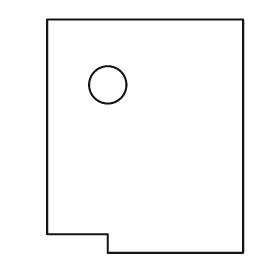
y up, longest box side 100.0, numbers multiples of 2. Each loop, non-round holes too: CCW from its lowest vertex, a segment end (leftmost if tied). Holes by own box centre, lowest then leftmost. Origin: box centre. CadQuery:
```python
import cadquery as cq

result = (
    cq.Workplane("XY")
    .moveTo(-16.0, -50.0)
    .lineTo(42.0, -50.0)
    .lineTo(42.0, 50.0)
    .lineTo(-42.0, 50.0)
    .lineTo(-42.0, -42.0)
    .lineTo(-16.0, -42.0)
    .close()
    .moveTo(-16.0, 22.0)
    .circle(8.0)
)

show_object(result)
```